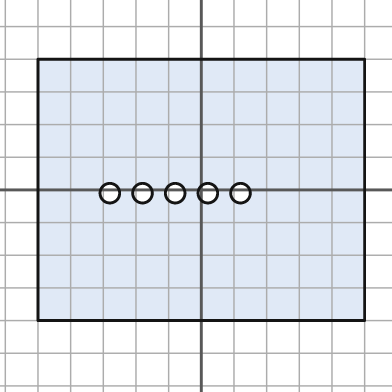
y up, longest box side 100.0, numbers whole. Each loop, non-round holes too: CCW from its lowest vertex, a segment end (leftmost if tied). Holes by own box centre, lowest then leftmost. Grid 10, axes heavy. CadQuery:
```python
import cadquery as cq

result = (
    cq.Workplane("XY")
    .moveTo(-50.0, -40.0)
    .lineTo(50.0, -40.0)
    .lineTo(50.0, 40.0)
    .lineTo(-50.0, 40.0)
    .close()
    .moveTo(-28.0, -1.0)
    .circle(3.0)
    .moveTo(-18.0, -1.0)
    .circle(3.0)
    .moveTo(-8.0, -1.0)
    .circle(3.0)
    .moveTo(2.0, -1.0)
    .circle(3.0)
    .moveTo(12.0, -1.0)
    .circle(3.0)
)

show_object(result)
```